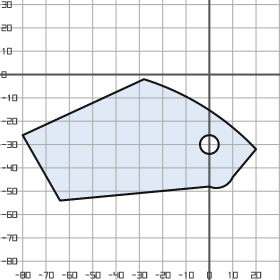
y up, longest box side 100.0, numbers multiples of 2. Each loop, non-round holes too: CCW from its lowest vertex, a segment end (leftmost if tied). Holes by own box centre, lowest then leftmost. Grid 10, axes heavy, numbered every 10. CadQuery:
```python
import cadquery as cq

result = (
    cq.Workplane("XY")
    .moveTo(-64.0, -54.0)
    .lineTo(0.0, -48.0)
    .threePointArc((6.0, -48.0), (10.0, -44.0))
    .lineTo(20.0, -32.0)
    .threePointArc((-2.0, -14.0), (-28.0, -2.0))
    .lineTo(-80.0, -26.0)
    .close()
    .moveTo(0.0, -30.0)
    .circle(4.0)
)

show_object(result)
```